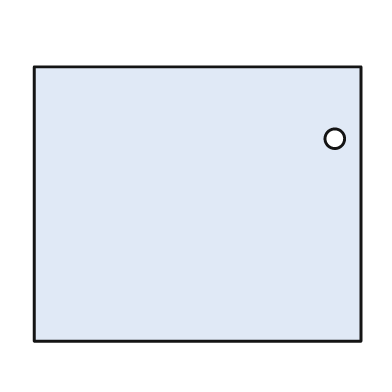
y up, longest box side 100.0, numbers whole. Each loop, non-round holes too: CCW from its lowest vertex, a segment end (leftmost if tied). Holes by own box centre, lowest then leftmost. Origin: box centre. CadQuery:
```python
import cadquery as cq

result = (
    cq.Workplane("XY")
    .moveTo(-50.0, -42.0)
    .lineTo(50.0, -42.0)
    .lineTo(50.0, 42.0)
    .lineTo(-50.0, 42.0)
    .close()
    .moveTo(42.0, 20.0)
    .circle(3.0)
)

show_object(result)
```